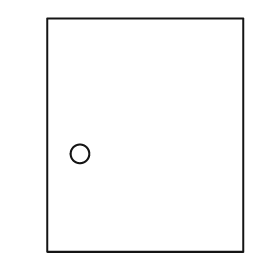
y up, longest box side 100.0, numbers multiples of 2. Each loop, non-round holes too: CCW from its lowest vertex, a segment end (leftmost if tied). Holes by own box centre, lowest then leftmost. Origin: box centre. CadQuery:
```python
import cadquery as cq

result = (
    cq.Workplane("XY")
    .moveTo(-42.0, -50.0)
    .lineTo(42.0, -50.0)
    .lineTo(42.0, 50.0)
    .lineTo(-42.0, 50.0)
    .close()
    .moveTo(-28.0, -8.0)
    .circle(4.0)
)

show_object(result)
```